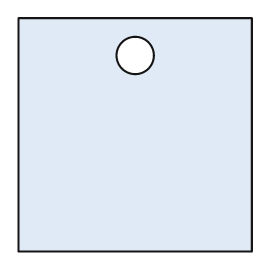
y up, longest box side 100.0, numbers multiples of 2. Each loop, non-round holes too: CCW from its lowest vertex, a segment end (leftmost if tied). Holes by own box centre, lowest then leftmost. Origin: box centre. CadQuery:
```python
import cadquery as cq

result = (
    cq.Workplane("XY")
    .moveTo(-50.0, -50.0)
    .lineTo(50.0, -50.0)
    .lineTo(50.0, 50.0)
    .lineTo(-50.0, 50.0)
    .close()
    .moveTo(0.0, 34.0)
    .circle(8.0)
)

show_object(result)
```